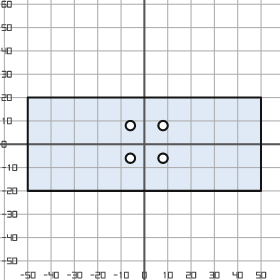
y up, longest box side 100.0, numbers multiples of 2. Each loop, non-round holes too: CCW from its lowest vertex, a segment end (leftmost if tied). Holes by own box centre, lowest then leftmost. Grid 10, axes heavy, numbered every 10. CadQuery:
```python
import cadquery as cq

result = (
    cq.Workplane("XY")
    .moveTo(-50.0, -20.0)
    .lineTo(50.0, -20.0)
    .lineTo(50.0, 20.0)
    .lineTo(-50.0, 20.0)
    .close()
    .moveTo(-6.0, -6.0)
    .circle(2.0)
    .moveTo(8.0, -6.0)
    .circle(2.0)
    .moveTo(-6.0, 8.0)
    .circle(2.0)
    .moveTo(8.0, 8.0)
    .circle(2.0)
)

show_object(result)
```